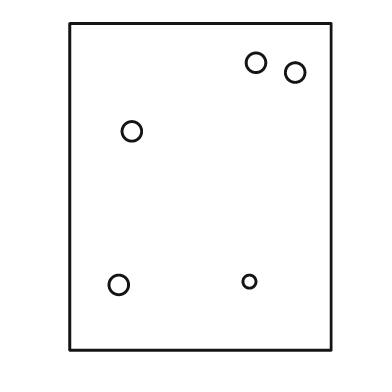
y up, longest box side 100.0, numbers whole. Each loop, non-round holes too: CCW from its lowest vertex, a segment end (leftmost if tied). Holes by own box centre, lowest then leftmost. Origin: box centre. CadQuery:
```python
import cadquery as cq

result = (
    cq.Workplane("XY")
    .moveTo(-40.0, -50.0)
    .lineTo(40.0, -50.0)
    .lineTo(40.0, 50.0)
    .lineTo(-40.0, 50.0)
    .close()
    .moveTo(-25.0, -30.0)
    .circle(3.0)
    .moveTo(15.0, -29.0)
    .circle(2.0)
    .moveTo(-21.0, 17.0)
    .circle(3.0)
    .moveTo(29.0, 35.0)
    .circle(3.0)
    .moveTo(17.0, 38.0)
    .circle(3.0)
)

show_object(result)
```